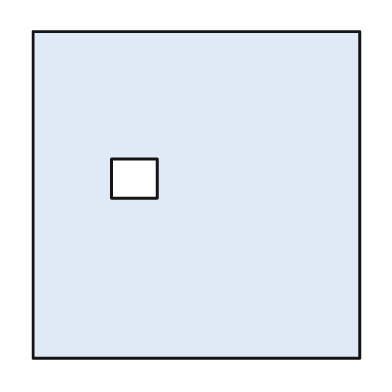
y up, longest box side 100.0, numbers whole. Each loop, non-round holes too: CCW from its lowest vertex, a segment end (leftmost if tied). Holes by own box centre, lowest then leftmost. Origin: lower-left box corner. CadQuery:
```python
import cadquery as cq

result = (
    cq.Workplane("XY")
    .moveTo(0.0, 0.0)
    .lineTo(100.0, 0.0)
    .lineTo(100.0, 100.0)
    .lineTo(0.0, 100.0)
    .close()
    .moveTo(24.0, 49.0)
    .lineTo(38.0, 49.0)
    .lineTo(38.0, 61.0)
    .lineTo(24.0, 61.0)
    .close()
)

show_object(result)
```